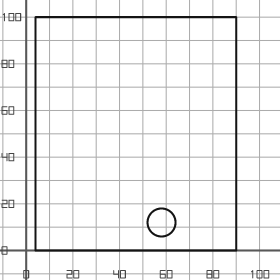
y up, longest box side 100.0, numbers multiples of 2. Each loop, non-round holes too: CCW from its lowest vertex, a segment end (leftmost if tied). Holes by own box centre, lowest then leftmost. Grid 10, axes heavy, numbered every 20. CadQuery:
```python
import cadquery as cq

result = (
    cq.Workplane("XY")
    .moveTo(4.0, 0.0)
    .lineTo(90.0, 0.0)
    .lineTo(90.0, 100.0)
    .lineTo(4.0, 100.0)
    .close()
    .moveTo(58.0, 12.0)
    .circle(6.0)
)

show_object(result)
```